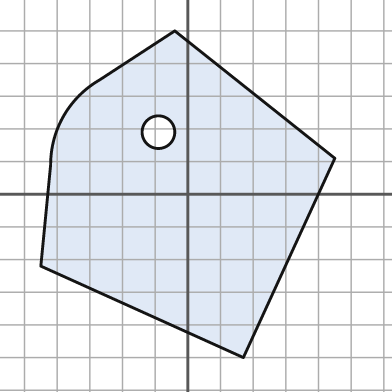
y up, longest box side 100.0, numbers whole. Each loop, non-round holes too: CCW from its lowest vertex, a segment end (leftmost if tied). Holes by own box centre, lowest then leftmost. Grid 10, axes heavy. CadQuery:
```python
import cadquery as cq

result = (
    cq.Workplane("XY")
    .moveTo(17.0, -50.0)
    .lineTo(45.0, 11.0)
    .lineTo(-4.0, 50.0)
    .lineTo(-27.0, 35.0)
    .threePointArc((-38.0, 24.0), (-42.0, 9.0))
    .lineTo(-45.0, -22.0)
    .close()
    .moveTo(-9.0, 19.0)
    .circle(5.0)
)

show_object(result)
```